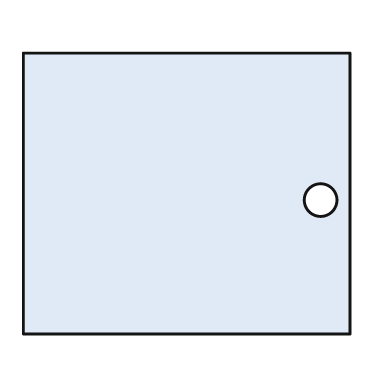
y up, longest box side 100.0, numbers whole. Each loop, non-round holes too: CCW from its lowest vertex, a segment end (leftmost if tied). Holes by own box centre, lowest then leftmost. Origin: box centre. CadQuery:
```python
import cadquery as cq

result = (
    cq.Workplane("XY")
    .moveTo(-50.0, -43.0)
    .lineTo(50.0, -43.0)
    .lineTo(50.0, 43.0)
    .lineTo(-50.0, 43.0)
    .close()
    .moveTo(41.0, -2.0)
    .circle(5.0)
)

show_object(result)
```